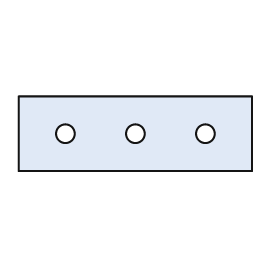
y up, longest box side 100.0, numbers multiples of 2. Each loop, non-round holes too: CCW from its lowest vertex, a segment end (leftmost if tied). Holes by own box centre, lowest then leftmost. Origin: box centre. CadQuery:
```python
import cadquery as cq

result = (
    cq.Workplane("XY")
    .moveTo(-50.0, -16.0)
    .lineTo(50.0, -16.0)
    .lineTo(50.0, 16.0)
    .lineTo(-50.0, 16.0)
    .close()
    .moveTo(-30.0, 0.0)
    .circle(4.0)
    .moveTo(0.0, 0.0)
    .circle(4.0)
    .moveTo(30.0, 0.0)
    .circle(4.0)
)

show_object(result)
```